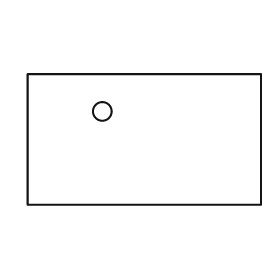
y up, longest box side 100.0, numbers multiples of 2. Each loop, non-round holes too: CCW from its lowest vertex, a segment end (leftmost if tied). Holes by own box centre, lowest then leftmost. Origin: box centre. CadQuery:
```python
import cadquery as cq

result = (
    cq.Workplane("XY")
    .moveTo(-50.0, -28.0)
    .lineTo(50.0, -28.0)
    .lineTo(50.0, 28.0)
    .lineTo(-50.0, 28.0)
    .close()
    .moveTo(-18.0, 12.0)
    .circle(4.0)
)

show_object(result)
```